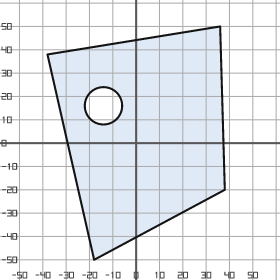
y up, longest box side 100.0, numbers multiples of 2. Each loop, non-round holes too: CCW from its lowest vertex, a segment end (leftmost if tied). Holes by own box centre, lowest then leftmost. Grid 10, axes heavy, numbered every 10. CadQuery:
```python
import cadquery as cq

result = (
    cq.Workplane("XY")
    .moveTo(-18.0, -50.0)
    .lineTo(38.0, -20.0)
    .lineTo(36.0, 50.0)
    .lineTo(-38.0, 38.0)
    .close()
    .moveTo(-14.0, 16.0)
    .circle(8.0)
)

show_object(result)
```